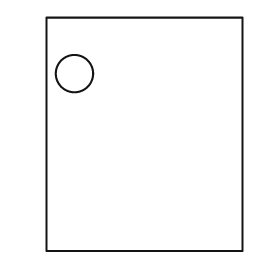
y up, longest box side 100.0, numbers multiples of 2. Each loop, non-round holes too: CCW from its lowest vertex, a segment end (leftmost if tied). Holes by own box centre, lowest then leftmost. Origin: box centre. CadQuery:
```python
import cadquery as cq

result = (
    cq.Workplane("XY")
    .moveTo(-42.0, -50.0)
    .lineTo(42.0, -50.0)
    .lineTo(42.0, 50.0)
    .lineTo(-42.0, 50.0)
    .close()
    .moveTo(-30.0, 26.0)
    .circle(8.0)
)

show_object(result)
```